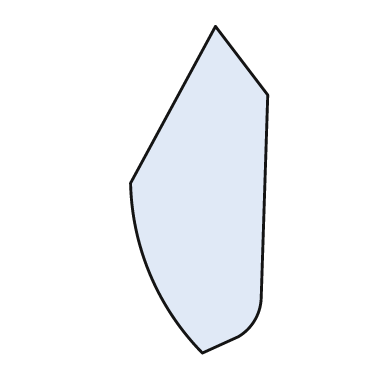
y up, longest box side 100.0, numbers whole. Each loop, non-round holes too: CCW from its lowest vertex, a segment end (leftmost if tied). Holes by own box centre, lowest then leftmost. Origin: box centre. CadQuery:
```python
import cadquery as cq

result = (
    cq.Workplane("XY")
    .moveTo(1.0, -50.0)
    .lineTo(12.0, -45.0)
    .threePointArc((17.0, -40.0), (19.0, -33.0))
    .lineTo(21.0, 29.0)
    .lineTo(5.0, 50.0)
    .lineTo(-21.0, 2.0)
    .threePointArc((-15.0, -26.0), (1.0, -50.0))
    .close()
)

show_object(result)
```